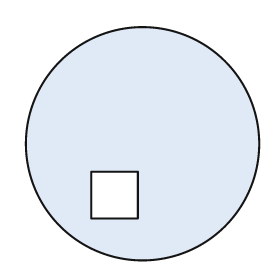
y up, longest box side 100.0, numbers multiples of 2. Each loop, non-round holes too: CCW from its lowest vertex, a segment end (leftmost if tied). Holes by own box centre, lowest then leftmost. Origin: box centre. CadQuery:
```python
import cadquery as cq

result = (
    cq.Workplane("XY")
    .moveTo(0.0, 0.0)
    .circle(50.0)
    .moveTo(-22.0, -32.0)
    .lineTo(-2.0, -32.0)
    .lineTo(-2.0, -12.0)
    .lineTo(-22.0, -12.0)
    .close()
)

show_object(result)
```